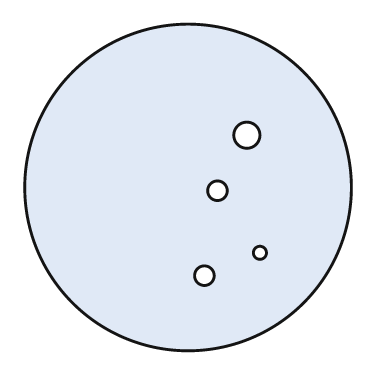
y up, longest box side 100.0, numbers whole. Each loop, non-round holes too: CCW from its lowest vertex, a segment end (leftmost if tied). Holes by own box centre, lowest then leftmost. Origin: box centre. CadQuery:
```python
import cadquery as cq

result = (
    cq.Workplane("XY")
    .moveTo(0.0, 0.0)
    .circle(50.0)
    .moveTo(5.0, -27.0)
    .circle(3.0)
    .moveTo(22.0, -20.0)
    .circle(2.0)
    .moveTo(9.0, -1.0)
    .circle(3.0)
    .moveTo(18.0, 16.0)
    .circle(4.0)
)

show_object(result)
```